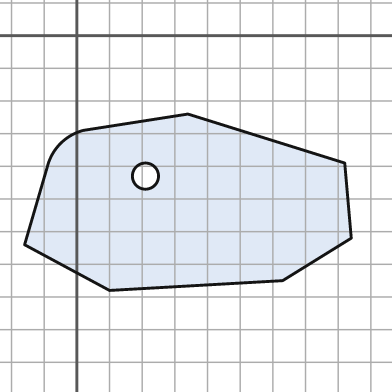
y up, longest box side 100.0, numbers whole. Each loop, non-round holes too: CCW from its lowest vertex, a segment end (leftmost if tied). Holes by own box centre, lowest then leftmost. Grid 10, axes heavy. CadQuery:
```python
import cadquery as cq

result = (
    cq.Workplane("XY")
    .moveTo(10.0, -78.0)
    .lineTo(63.0, -75.0)
    .lineTo(84.0, -62.0)
    .lineTo(82.0, -39.0)
    .lineTo(34.0, -24.0)
    .lineTo(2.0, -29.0)
    .threePointArc((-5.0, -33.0), (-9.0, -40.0))
    .lineTo(-16.0, -64.0)
    .close()
    .moveTo(21.0, -43.0)
    .circle(4.0)
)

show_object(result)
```